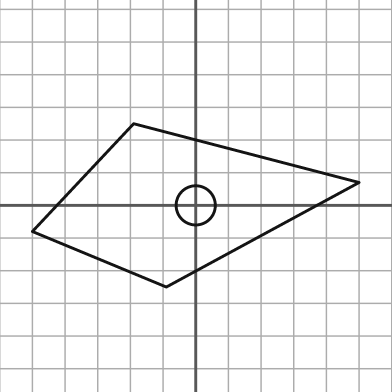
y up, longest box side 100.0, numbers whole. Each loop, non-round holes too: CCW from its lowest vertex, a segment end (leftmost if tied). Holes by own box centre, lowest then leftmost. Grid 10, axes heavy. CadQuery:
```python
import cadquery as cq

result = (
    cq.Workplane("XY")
    .moveTo(-9.0, -25.0)
    .lineTo(50.0, 7.0)
    .lineTo(-19.0, 25.0)
    .lineTo(-50.0, -8.0)
    .close()
    .moveTo(0.0, 0.0)
    .circle(6.0)
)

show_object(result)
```